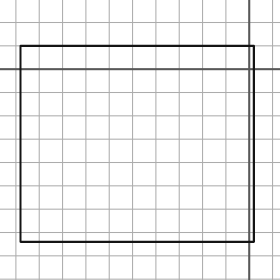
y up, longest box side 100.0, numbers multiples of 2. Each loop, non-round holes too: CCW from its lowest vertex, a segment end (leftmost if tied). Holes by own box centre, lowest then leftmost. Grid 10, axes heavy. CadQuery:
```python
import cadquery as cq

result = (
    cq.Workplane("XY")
    .moveTo(-98.0, -74.0)
    .lineTo(2.0, -74.0)
    .lineTo(2.0, 10.0)
    .lineTo(-98.0, 10.0)
    .close()
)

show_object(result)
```